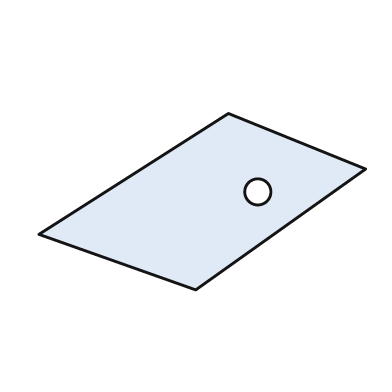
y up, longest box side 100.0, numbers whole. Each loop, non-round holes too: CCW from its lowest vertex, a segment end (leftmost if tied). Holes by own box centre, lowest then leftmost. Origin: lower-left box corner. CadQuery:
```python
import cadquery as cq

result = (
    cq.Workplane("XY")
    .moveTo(48.0, 0.0)
    .lineTo(100.0, 37.0)
    .lineTo(58.0, 54.0)
    .lineTo(0.0, 17.0)
    .close()
    .moveTo(67.0, 30.0)
    .circle(4.0)
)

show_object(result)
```